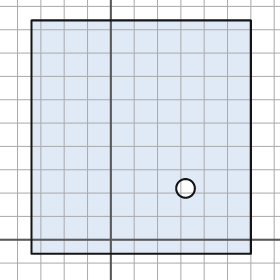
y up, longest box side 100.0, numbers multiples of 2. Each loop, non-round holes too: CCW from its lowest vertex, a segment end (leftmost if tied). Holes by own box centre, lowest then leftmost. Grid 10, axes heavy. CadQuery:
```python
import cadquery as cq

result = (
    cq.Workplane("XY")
    .moveTo(-34.0, -6.0)
    .lineTo(60.0, -6.0)
    .lineTo(60.0, 94.0)
    .lineTo(-34.0, 94.0)
    .close()
    .moveTo(32.0, 22.0)
    .circle(4.0)
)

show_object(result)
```